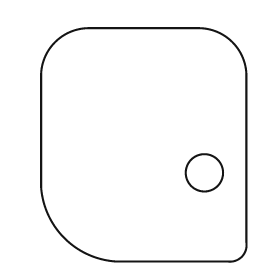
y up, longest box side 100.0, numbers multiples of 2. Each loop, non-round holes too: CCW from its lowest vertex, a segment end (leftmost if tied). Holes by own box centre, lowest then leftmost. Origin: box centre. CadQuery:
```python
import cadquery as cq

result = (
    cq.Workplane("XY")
    .moveTo(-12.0, -50.0)
    .lineTo(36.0, -50.0)
    .threePointArc((42.0, -48.0), (44.0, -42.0))
    .lineTo(44.0, 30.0)
    .threePointArc((38.0, 44.0), (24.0, 50.0))
    .lineTo(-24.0, 50.0)
    .threePointArc((-38.0, 44.0), (-44.0, 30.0))
    .lineTo(-44.0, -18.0)
    .threePointArc((-34.0, -40.0), (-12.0, -50.0))
    .close()
    .moveTo(26.0, -12.0)
    .circle(8.0)
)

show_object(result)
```